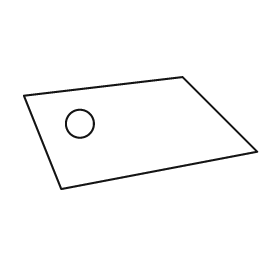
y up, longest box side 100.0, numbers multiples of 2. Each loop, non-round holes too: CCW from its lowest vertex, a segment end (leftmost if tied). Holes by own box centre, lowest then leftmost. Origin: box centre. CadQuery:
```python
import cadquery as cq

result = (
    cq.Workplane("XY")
    .moveTo(-34.0, -24.0)
    .lineTo(50.0, -8.0)
    .lineTo(18.0, 24.0)
    .lineTo(-50.0, 16.0)
    .close()
    .moveTo(-26.0, 4.0)
    .circle(6.0)
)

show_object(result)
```